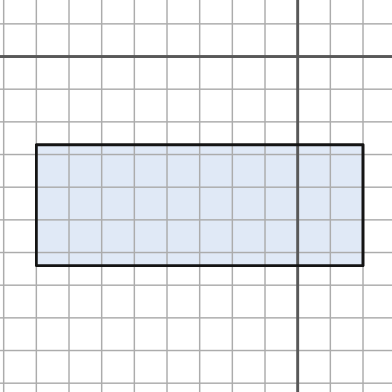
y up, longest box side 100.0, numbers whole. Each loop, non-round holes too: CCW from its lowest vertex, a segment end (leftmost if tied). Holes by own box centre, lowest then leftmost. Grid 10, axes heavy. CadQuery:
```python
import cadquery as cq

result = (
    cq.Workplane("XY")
    .moveTo(-80.0, -64.0)
    .lineTo(20.0, -64.0)
    .lineTo(20.0, -27.0)
    .lineTo(-80.0, -27.0)
    .close()
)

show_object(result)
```